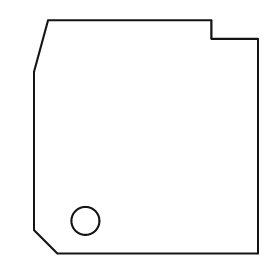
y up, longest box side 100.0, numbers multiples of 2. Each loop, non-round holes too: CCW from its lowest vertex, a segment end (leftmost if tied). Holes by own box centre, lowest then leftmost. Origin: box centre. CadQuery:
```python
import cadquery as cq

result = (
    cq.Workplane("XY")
    .moveTo(-38.0, -50.0)
    .lineTo(48.0, -50.0)
    .lineTo(48.0, 42.0)
    .lineTo(28.0, 42.0)
    .lineTo(28.0, 50.0)
    .lineTo(-42.0, 50.0)
    .lineTo(-48.0, 28.0)
    .lineTo(-48.0, -40.0)
    .close()
    .moveTo(-26.0, -36.0)
    .circle(6.0)
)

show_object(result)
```